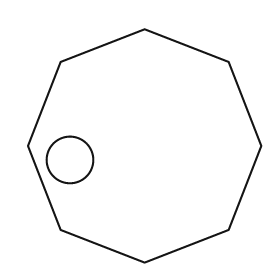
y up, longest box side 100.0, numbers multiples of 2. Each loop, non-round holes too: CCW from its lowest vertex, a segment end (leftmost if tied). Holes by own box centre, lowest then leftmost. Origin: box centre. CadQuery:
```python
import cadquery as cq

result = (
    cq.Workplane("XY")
    .moveTo(0.0, -50.0)
    .lineTo(36.0, -36.0)
    .lineTo(50.0, 0.0)
    .lineTo(36.0, 36.0)
    .lineTo(0.0, 50.0)
    .lineTo(-36.0, 36.0)
    .lineTo(-50.0, 0.0)
    .lineTo(-36.0, -36.0)
    .close()
    .moveTo(-32.0, -6.0)
    .circle(10.0)
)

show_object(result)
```